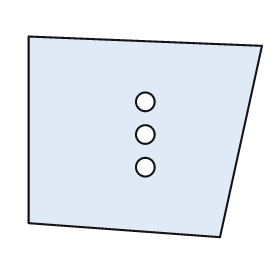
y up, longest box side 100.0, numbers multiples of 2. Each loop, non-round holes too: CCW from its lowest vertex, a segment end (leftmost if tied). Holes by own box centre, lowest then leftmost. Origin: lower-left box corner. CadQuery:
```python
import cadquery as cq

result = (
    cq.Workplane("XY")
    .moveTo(82.0, 0.0)
    .lineTo(100.0, 82.0)
    .lineTo(0.0, 86.0)
    .lineTo(0.0, 6.0)
    .close()
    .moveTo(50.0, 30.0)
    .circle(4.0)
    .moveTo(50.0, 44.0)
    .circle(4.0)
    .moveTo(50.0, 58.0)
    .circle(4.0)
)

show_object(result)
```